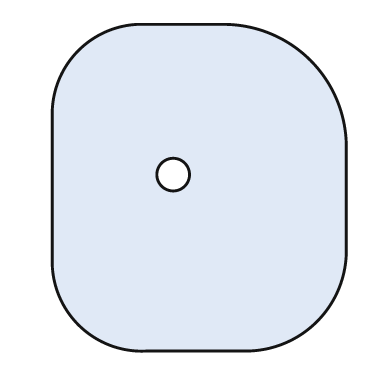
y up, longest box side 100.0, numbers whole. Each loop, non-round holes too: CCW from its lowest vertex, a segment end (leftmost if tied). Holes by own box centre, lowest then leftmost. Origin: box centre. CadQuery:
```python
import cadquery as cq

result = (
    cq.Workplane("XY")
    .moveTo(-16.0, -50.0)
    .lineTo(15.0, -50.0)
    .threePointArc((36.0, -41.0), (45.0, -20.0))
    .lineTo(45.0, 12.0)
    .threePointArc((34.0, 39.0), (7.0, 50.0))
    .lineTo(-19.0, 50.0)
    .threePointArc((-37.0, 42.0), (-45.0, 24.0))
    .lineTo(-45.0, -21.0)
    .threePointArc((-37.0, -42.0), (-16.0, -50.0))
    .close()
    .moveTo(-8.0, 4.0)
    .circle(5.0)
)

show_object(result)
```